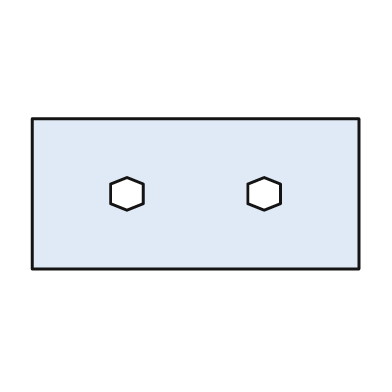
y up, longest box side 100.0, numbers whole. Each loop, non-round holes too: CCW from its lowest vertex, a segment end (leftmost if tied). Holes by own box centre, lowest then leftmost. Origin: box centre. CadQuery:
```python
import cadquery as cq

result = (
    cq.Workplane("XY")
    .moveTo(-50.0, -23.0)
    .lineTo(50.0, -23.0)
    .lineTo(50.0, 23.0)
    .lineTo(-50.0, 23.0)
    .close()
    .moveTo(-21.0, -5.0)
    .lineTo(-16.0, -3.0)
    .lineTo(-16.0, 3.0)
    .lineTo(-21.0, 5.0)
    .lineTo(-26.0, 3.0)
    .lineTo(-26.0, -3.0)
    .close()
    .moveTo(21.0, -5.0)
    .lineTo(26.0, -3.0)
    .lineTo(26.0, 3.0)
    .lineTo(21.0, 5.0)
    .lineTo(16.0, 3.0)
    .lineTo(16.0, -3.0)
    .close()
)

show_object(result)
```